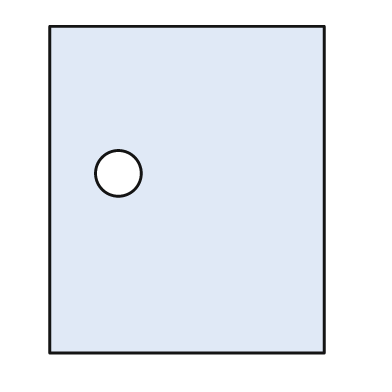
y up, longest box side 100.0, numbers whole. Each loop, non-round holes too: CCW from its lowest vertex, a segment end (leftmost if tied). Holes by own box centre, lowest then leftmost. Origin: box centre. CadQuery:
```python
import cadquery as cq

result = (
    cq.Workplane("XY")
    .moveTo(-42.0, -50.0)
    .lineTo(42.0, -50.0)
    .lineTo(42.0, 50.0)
    .lineTo(-42.0, 50.0)
    .close()
    .moveTo(-21.0, 5.0)
    .circle(7.0)
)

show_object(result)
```